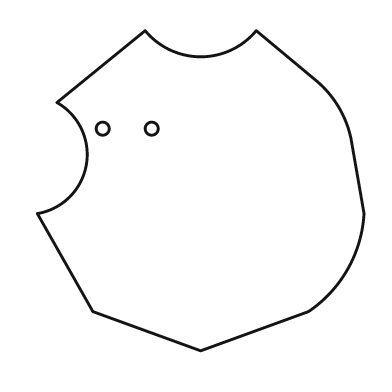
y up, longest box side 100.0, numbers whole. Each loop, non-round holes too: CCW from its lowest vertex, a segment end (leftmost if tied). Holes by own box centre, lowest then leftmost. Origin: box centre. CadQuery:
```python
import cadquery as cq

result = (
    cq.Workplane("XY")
    .moveTo(0.0, -49.0)
    .lineTo(33.0, -37.0)
    .threePointArc((45.0, -24.0), (50.0, -7.0))
    .lineTo(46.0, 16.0)
    .threePointArc((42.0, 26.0), (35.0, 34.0))
    .lineTo(17.0, 49.0)
    .threePointArc((0.0, 41.0), (-17.0, 49.0))
    .lineTo(-44.0, 27.0)
    .threePointArc((-35.0, 8.0), (-50.0, -7.0))
    .lineTo(-33.0, -37.0)
    .close()
    .moveTo(-30.0, 19.0)
    .circle(2.0)
    .moveTo(-15.0, 19.0)
    .circle(2.0)
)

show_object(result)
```